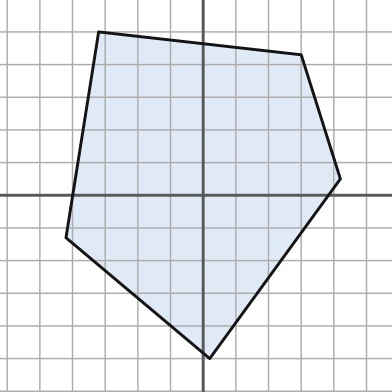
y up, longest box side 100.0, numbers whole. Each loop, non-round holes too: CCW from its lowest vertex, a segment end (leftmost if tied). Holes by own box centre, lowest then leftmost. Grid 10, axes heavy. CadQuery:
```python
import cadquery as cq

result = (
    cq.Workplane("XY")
    .moveTo(2.0, -50.0)
    .lineTo(42.0, 5.0)
    .lineTo(30.0, 43.0)
    .lineTo(-32.0, 50.0)
    .lineTo(-42.0, -13.0)
    .close()
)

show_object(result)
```